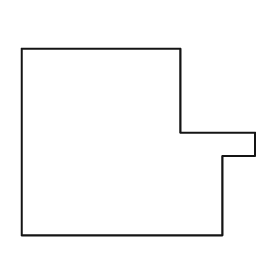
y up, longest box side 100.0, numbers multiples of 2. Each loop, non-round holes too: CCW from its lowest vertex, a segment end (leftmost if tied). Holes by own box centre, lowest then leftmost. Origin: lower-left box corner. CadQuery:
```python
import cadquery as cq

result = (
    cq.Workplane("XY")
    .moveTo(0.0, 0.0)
    .lineTo(86.0, 0.0)
    .lineTo(86.0, 34.0)
    .lineTo(100.0, 34.0)
    .lineTo(100.0, 44.0)
    .lineTo(68.0, 44.0)
    .lineTo(68.0, 80.0)
    .lineTo(0.0, 80.0)
    .close()
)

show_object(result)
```